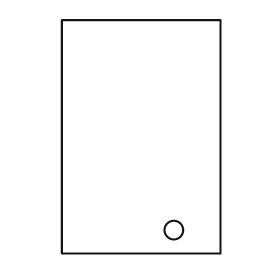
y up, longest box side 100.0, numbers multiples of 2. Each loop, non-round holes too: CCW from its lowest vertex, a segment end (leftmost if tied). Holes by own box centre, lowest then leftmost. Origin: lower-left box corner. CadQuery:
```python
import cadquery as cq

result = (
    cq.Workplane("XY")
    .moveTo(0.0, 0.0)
    .lineTo(68.0, 0.0)
    .lineTo(68.0, 100.0)
    .lineTo(0.0, 100.0)
    .close()
    .moveTo(48.0, 10.0)
    .circle(4.0)
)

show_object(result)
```